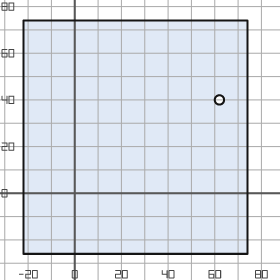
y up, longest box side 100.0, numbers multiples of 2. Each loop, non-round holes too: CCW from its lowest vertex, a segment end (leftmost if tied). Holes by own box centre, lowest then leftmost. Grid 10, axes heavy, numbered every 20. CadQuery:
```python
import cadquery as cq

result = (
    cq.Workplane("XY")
    .moveTo(-22.0, -26.0)
    .lineTo(74.0, -26.0)
    .lineTo(74.0, 74.0)
    .lineTo(-22.0, 74.0)
    .close()
    .moveTo(62.0, 40.0)
    .circle(2.0)
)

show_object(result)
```